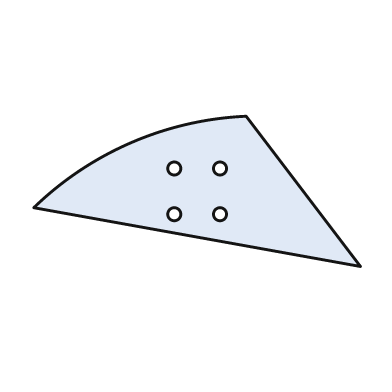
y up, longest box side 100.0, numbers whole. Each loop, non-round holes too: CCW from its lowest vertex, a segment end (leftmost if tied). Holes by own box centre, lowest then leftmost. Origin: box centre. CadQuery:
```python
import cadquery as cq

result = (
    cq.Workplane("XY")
    .moveTo(50.0, -23.0)
    .lineTo(15.0, 23.0)
    .threePointArc((-20.0, 15.0), (-50.0, -5.0))
    .close()
    .moveTo(-7.0, -7.0)
    .circle(2.0)
    .moveTo(7.0, -7.0)
    .circle(2.0)
    .moveTo(-7.0, 7.0)
    .circle(2.0)
    .moveTo(7.0, 7.0)
    .circle(2.0)
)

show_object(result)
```